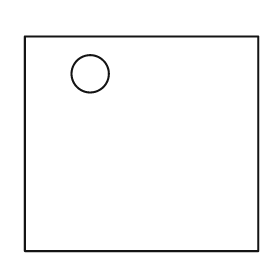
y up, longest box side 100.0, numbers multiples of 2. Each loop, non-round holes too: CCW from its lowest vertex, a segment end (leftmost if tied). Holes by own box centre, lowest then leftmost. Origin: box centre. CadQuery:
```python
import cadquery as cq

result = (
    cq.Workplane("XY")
    .moveTo(-50.0, -46.0)
    .lineTo(50.0, -46.0)
    .lineTo(50.0, 46.0)
    .lineTo(-50.0, 46.0)
    .close()
    .moveTo(-22.0, 30.0)
    .circle(8.0)
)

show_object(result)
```